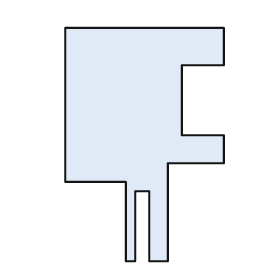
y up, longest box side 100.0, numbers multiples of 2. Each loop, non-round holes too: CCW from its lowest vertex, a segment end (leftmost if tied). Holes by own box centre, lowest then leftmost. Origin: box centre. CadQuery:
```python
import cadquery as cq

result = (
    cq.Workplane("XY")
    .moveTo(-8.0, -50.0)
    .lineTo(-4.0, -50.0)
    .lineTo(-4.0, -20.0)
    .lineTo(2.0, -20.0)
    .lineTo(2.0, -50.0)
    .lineTo(10.0, -50.0)
    .lineTo(10.0, -8.0)
    .lineTo(34.0, -8.0)
    .lineTo(34.0, 4.0)
    .lineTo(16.0, 4.0)
    .lineTo(16.0, 34.0)
    .lineTo(34.0, 34.0)
    .lineTo(34.0, 50.0)
    .lineTo(-34.0, 50.0)
    .lineTo(-34.0, -16.0)
    .lineTo(-8.0, -16.0)
    .close()
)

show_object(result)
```